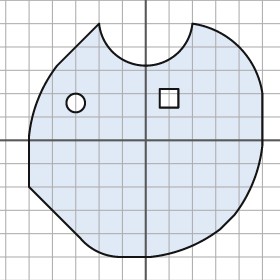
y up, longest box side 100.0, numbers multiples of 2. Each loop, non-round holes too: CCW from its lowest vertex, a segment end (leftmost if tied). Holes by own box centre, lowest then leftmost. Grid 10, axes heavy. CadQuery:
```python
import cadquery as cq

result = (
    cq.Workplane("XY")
    .moveTo(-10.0, -50.0)
    .lineTo(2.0, -50.0)
    .threePointArc((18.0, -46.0), (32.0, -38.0))
    .lineTo(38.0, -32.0)
    .threePointArc((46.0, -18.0), (50.0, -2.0))
    .lineTo(50.0, 20.0)
    .threePointArc((40.0, 40.0), (20.0, 50.0))
    .threePointArc((0.0, 32.0), (-20.0, 50.0))
    .lineTo(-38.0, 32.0)
    .threePointArc((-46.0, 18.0), (-50.0, 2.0))
    .lineTo(-50.0, -20.0)
    .lineTo(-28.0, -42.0)
    .threePointArc((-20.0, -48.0), (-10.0, -50.0))
    .close()
    .moveTo(-30.0, 16.0)
    .circle(4.0)
    .moveTo(6.0, 14.0)
    .lineTo(14.0, 14.0)
    .lineTo(14.0, 22.0)
    .lineTo(6.0, 22.0)
    .close()
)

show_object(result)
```